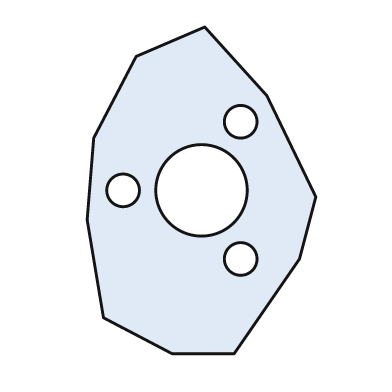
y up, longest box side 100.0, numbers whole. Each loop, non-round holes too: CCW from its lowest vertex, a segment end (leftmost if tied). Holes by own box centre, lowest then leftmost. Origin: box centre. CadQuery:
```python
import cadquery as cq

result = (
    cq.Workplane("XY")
    .moveTo(-9.0, -50.0)
    .lineTo(10.0, -50.0)
    .lineTo(30.0, -21.0)
    .lineTo(35.0, -2.0)
    .lineTo(20.0, 29.0)
    .lineTo(1.0, 50.0)
    .lineTo(-20.0, 41.0)
    .lineTo(-33.0, 16.0)
    .lineTo(-35.0, -9.0)
    .lineTo(-30.0, -39.0)
    .close()
    .moveTo(12.0, -21.0)
    .circle(5.0)
    .moveTo(-24.0, 0.0)
    .circle(5.0)
    .moveTo(0.0, 0.0)
    .circle(14.0)
    .moveTo(12.0, 21.0)
    .circle(5.0)
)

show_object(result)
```